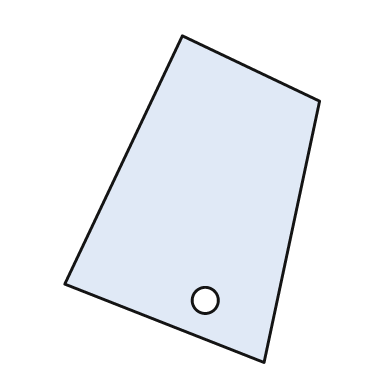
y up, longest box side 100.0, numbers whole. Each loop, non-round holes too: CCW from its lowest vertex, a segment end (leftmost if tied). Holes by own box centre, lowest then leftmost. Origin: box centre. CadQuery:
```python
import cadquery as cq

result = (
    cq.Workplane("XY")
    .moveTo(22.0, -50.0)
    .lineTo(39.0, 30.0)
    .lineTo(-3.0, 50.0)
    .lineTo(-39.0, -26.0)
    .close()
    .moveTo(4.0, -31.0)
    .circle(4.0)
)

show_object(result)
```